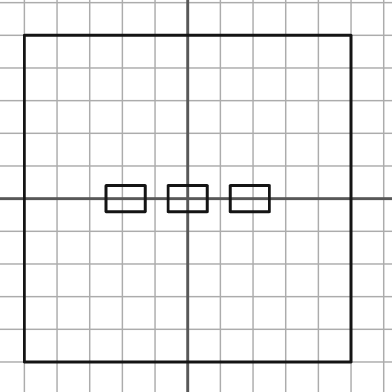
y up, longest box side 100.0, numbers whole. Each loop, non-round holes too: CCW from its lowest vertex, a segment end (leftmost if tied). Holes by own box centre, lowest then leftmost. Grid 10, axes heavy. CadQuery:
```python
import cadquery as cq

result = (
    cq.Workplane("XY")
    .moveTo(-50.0, -50.0)
    .lineTo(50.0, -50.0)
    .lineTo(50.0, 50.0)
    .lineTo(-50.0, 50.0)
    .close()
    .moveTo(-25.0, -4.0)
    .lineTo(-13.0, -4.0)
    .lineTo(-13.0, 4.0)
    .lineTo(-25.0, 4.0)
    .close()
    .moveTo(-6.0, -4.0)
    .lineTo(6.0, -4.0)
    .lineTo(6.0, 4.0)
    .lineTo(-6.0, 4.0)
    .close()
    .moveTo(13.0, -4.0)
    .lineTo(25.0, -4.0)
    .lineTo(25.0, 4.0)
    .lineTo(13.0, 4.0)
    .close()
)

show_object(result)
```